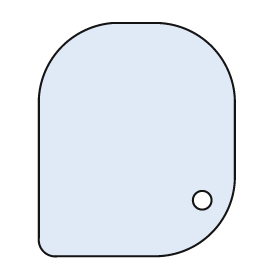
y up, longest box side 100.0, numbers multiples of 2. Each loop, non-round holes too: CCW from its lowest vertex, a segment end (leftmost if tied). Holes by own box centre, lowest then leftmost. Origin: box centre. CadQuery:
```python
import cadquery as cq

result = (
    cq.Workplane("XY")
    .moveTo(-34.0, -50.0)
    .lineTo(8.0, -50.0)
    .threePointArc((32.0, -40.0), (42.0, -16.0))
    .lineTo(42.0, 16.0)
    .threePointArc((32.0, 40.0), (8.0, 50.0))
    .lineTo(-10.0, 50.0)
    .threePointArc((-32.0, 40.0), (-42.0, 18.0))
    .lineTo(-42.0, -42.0)
    .threePointArc((-40.0, -48.0), (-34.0, -50.0))
    .close()
    .moveTo(28.0, -26.0)
    .circle(4.0)
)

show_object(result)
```